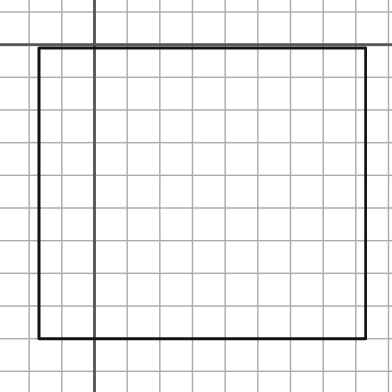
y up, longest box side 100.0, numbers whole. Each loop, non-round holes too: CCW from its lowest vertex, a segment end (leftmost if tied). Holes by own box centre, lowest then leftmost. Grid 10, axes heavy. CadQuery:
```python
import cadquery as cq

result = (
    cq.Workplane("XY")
    .moveTo(-17.0, -90.0)
    .lineTo(83.0, -90.0)
    .lineTo(83.0, -1.0)
    .lineTo(-17.0, -1.0)
    .close()
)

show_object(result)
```